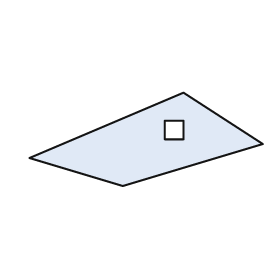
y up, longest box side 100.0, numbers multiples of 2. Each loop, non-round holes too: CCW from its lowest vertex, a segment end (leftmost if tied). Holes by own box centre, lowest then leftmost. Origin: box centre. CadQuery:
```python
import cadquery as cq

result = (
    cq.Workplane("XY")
    .moveTo(-10.0, -20.0)
    .lineTo(50.0, -2.0)
    .lineTo(16.0, 20.0)
    .lineTo(-50.0, -8.0)
    .close()
    .moveTo(8.0, 0.0)
    .lineTo(16.0, 0.0)
    .lineTo(16.0, 8.0)
    .lineTo(8.0, 8.0)
    .close()
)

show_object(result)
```